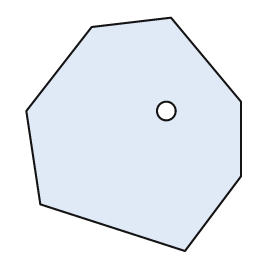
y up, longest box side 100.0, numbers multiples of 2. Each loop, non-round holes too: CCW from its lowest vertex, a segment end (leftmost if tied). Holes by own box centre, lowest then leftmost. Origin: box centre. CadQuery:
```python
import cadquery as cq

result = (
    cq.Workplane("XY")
    .moveTo(22.0, -50.0)
    .lineTo(46.0, -18.0)
    .lineTo(46.0, 14.0)
    .lineTo(16.0, 50.0)
    .lineTo(-18.0, 46.0)
    .lineTo(-46.0, 10.0)
    .lineTo(-40.0, -30.0)
    .close()
    .moveTo(14.0, 10.0)
    .circle(4.0)
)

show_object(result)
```